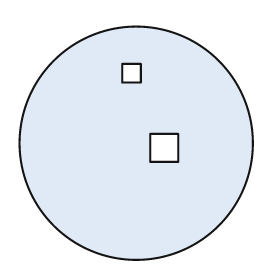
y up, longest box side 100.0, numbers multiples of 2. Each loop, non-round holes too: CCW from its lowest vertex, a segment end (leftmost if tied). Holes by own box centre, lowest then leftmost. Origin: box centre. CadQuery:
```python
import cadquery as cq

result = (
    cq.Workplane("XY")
    .moveTo(0.0, 0.0)
    .circle(50.0)
    .moveTo(6.0, -8.0)
    .lineTo(18.0, -8.0)
    .lineTo(18.0, 4.0)
    .lineTo(6.0, 4.0)
    .close()
    .moveTo(-6.0, 26.0)
    .lineTo(2.0, 26.0)
    .lineTo(2.0, 34.0)
    .lineTo(-6.0, 34.0)
    .close()
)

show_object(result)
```